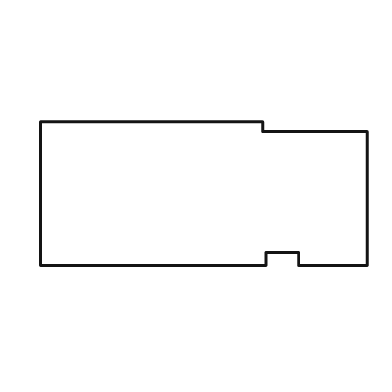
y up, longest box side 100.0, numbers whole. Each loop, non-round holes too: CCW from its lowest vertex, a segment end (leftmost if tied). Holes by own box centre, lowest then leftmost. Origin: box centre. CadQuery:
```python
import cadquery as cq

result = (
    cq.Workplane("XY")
    .moveTo(-50.0, -22.0)
    .lineTo(19.0, -22.0)
    .lineTo(19.0, -18.0)
    .lineTo(29.0, -18.0)
    .lineTo(29.0, -22.0)
    .lineTo(50.0, -22.0)
    .lineTo(50.0, 19.0)
    .lineTo(18.0, 19.0)
    .lineTo(18.0, 22.0)
    .lineTo(-50.0, 22.0)
    .close()
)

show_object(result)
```